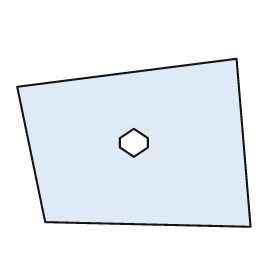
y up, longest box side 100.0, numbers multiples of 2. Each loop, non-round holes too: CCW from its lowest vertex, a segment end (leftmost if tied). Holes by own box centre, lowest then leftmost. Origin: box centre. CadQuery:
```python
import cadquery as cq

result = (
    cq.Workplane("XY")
    .moveTo(50.0, -36.0)
    .lineTo(44.0, 36.0)
    .lineTo(-50.0, 24.0)
    .lineTo(-38.0, -34.0)
    .close()
    .moveTo(0.0, -6.0)
    .lineTo(6.0, -2.0)
    .lineTo(6.0, 2.0)
    .lineTo(0.0, 6.0)
    .lineTo(-6.0, 2.0)
    .lineTo(-6.0, -2.0)
    .close()
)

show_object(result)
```